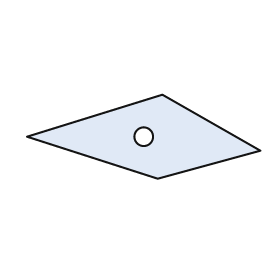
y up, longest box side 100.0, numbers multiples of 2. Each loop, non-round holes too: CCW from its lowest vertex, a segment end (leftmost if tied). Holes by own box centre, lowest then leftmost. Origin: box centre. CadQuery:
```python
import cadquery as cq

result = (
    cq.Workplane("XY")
    .moveTo(6.0, -18.0)
    .lineTo(50.0, -6.0)
    .lineTo(8.0, 18.0)
    .lineTo(-50.0, 0.0)
    .close()
    .moveTo(0.0, 0.0)
    .circle(4.0)
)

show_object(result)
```